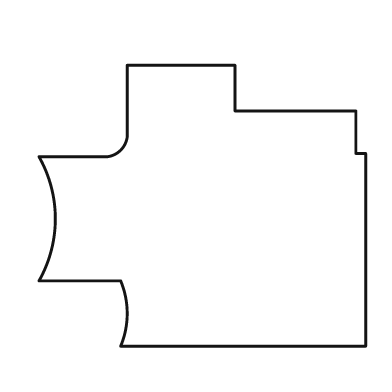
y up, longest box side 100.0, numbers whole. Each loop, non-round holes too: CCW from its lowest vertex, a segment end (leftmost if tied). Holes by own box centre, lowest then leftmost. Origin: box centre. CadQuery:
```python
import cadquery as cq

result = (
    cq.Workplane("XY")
    .moveTo(-25.0, -43.0)
    .lineTo(50.0, -43.0)
    .lineTo(50.0, 16.0)
    .lineTo(47.0, 16.0)
    .lineTo(47.0, 29.0)
    .lineTo(10.0, 29.0)
    .lineTo(10.0, 43.0)
    .lineTo(-23.0, 43.0)
    .lineTo(-23.0, 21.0)
    .threePointArc((-25.0, 17.0), (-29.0, 15.0))
    .lineTo(-50.0, 15.0)
    .threePointArc((-45.0, -4.0), (-50.0, -23.0))
    .lineTo(-25.0, -23.0)
    .threePointArc((-23.0, -33.0), (-25.0, -43.0))
    .close()
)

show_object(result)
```